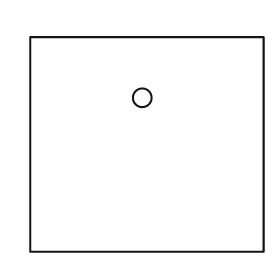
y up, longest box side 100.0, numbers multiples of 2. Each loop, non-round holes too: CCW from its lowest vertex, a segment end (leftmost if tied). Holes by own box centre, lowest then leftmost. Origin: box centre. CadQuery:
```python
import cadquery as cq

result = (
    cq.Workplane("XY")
    .moveTo(-50.0, -46.0)
    .lineTo(50.0, -46.0)
    .lineTo(50.0, 46.0)
    .lineTo(-50.0, 46.0)
    .close()
    .moveTo(-2.0, 20.0)
    .circle(4.0)
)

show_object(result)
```